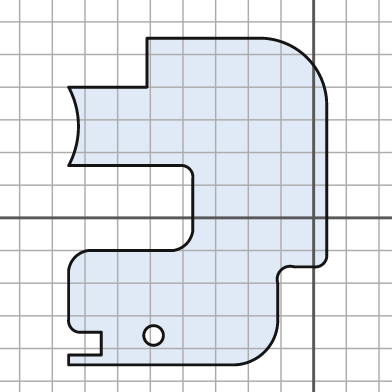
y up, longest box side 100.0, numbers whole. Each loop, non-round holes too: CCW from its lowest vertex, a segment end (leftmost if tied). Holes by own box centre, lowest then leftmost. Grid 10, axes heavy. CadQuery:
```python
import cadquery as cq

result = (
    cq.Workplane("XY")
    .moveTo(-75.0, -45.0)
    .lineTo(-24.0, -45.0)
    .threePointArc((-15.0, -41.0), (-11.0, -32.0))
    .lineTo(-11.0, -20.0)
    .threePointArc((-10.0, -16.0), (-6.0, -15.0))
    .lineTo(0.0, -15.0)
    .threePointArc((3.0, -14.0), (4.0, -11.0))
    .lineTo(4.0, 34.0)
    .threePointArc((-2.0, 49.0), (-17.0, 55.0))
    .lineTo(-51.0, 55.0)
    .lineTo(-51.0, 40.0)
    .lineTo(-75.0, 40.0)
    .threePointArc((-72.0, 28.0), (-75.0, 16.0))
    .lineTo(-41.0, 16.0)
    .threePointArc((-38.0, 15.0), (-37.0, 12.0))
    .lineTo(-37.0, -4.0)
    .threePointArc((-39.0, -8.0), (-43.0, -10.0))
    .lineTo(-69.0, -10.0)
    .threePointArc((-73.0, -12.0), (-75.0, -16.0))
    .lineTo(-75.0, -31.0)
    .threePointArc((-74.0, -34.0), (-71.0, -35.0))
    .lineTo(-65.0, -35.0)
    .lineTo(-65.0, -42.0)
    .lineTo(-75.0, -42.0)
    .close()
    .moveTo(-49.0, -36.0)
    .circle(3.0)
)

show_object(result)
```